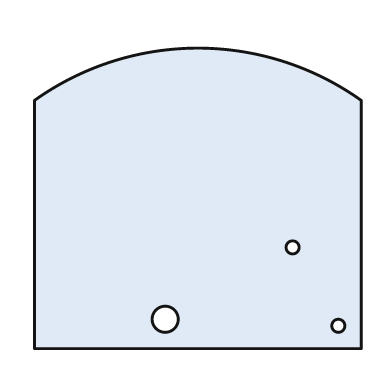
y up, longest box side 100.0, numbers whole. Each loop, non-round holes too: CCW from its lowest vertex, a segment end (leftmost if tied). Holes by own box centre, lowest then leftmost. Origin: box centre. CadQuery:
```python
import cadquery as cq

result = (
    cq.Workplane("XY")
    .moveTo(-50.0, -46.0)
    .lineTo(50.0, -46.0)
    .lineTo(50.0, 30.0)
    .threePointArc((0.0, 46.0), (-50.0, 30.0))
    .close()
    .moveTo(43.0, -39.0)
    .circle(2.0)
    .moveTo(-10.0, -37.0)
    .circle(4.0)
    .moveTo(29.0, -15.0)
    .circle(2.0)
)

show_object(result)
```